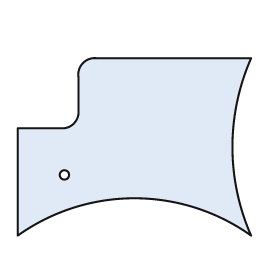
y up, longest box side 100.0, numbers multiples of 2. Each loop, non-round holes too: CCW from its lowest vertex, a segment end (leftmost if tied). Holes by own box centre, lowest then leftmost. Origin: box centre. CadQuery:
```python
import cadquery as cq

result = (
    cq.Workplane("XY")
    .moveTo(-50.0, -38.0)
    .threePointArc((0.0, -22.0), (50.0, -38.0))
    .threePointArc((42.0, 0.0), (50.0, 38.0))
    .lineTo(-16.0, 38.0)
    .threePointArc((-22.0, 36.0), (-24.0, 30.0))
    .lineTo(-24.0, 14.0)
    .threePointArc((-26.0, 10.0), (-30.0, 8.0))
    .lineTo(-50.0, 8.0)
    .close()
    .moveTo(-30.0, -12.0)
    .circle(2.0)
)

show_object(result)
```